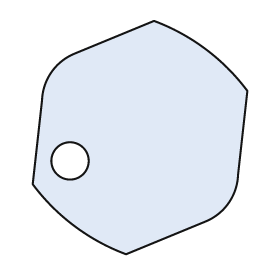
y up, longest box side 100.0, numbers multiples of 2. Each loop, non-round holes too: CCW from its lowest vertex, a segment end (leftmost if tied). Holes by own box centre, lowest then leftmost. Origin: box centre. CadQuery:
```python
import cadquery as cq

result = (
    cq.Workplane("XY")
    .moveTo(-6.0, -50.0)
    .lineTo(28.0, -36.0)
    .threePointArc((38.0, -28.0), (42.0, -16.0))
    .lineTo(46.0, 20.0)
    .threePointArc((28.0, 38.0), (6.0, 50.0))
    .lineTo(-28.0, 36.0)
    .threePointArc((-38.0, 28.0), (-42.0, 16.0))
    .lineTo(-46.0, -20.0)
    .threePointArc((-28.0, -38.0), (-6.0, -50.0))
    .close()
    .moveTo(-30.0, -10.0)
    .circle(8.0)
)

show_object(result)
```